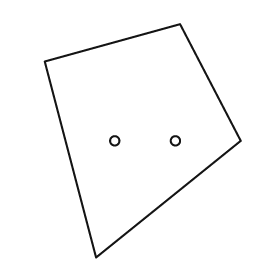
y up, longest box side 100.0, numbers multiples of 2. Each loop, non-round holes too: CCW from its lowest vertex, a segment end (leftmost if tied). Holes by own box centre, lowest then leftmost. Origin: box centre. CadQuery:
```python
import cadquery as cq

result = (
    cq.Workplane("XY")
    .moveTo(-20.0, -50.0)
    .lineTo(42.0, 0.0)
    .lineTo(16.0, 50.0)
    .lineTo(-42.0, 34.0)
    .close()
    .moveTo(-12.0, 0.0)
    .circle(2.0)
    .moveTo(14.0, 0.0)
    .circle(2.0)
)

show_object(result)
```